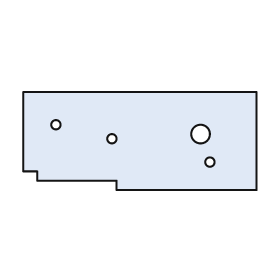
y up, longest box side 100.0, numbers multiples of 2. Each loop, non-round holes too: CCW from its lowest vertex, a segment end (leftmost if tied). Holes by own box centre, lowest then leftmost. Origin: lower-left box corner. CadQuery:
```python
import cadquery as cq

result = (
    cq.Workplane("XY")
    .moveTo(40.0, 0.0)
    .lineTo(100.0, 0.0)
    .lineTo(100.0, 42.0)
    .lineTo(0.0, 42.0)
    .lineTo(0.0, 8.0)
    .lineTo(6.0, 8.0)
    .lineTo(6.0, 4.0)
    .lineTo(40.0, 4.0)
    .close()
    .moveTo(80.0, 12.0)
    .circle(2.0)
    .moveTo(38.0, 22.0)
    .circle(2.0)
    .moveTo(76.0, 24.0)
    .circle(4.0)
    .moveTo(14.0, 28.0)
    .circle(2.0)
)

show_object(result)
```